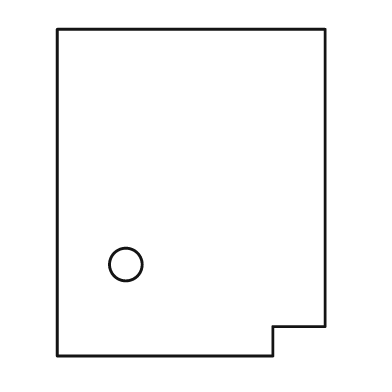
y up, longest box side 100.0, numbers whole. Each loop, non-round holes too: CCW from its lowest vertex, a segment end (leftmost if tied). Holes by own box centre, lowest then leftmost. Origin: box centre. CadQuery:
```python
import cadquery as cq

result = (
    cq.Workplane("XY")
    .moveTo(-41.0, -50.0)
    .lineTo(25.0, -50.0)
    .lineTo(25.0, -41.0)
    .lineTo(41.0, -41.0)
    .lineTo(41.0, 50.0)
    .lineTo(-41.0, 50.0)
    .close()
    .moveTo(-20.0, -22.0)
    .circle(5.0)
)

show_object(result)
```